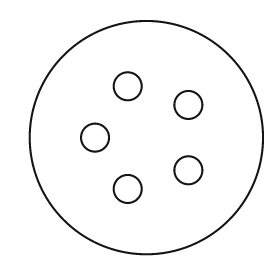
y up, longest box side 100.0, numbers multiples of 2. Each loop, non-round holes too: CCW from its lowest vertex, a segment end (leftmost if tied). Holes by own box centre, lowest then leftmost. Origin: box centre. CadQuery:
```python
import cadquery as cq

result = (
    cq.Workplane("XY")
    .moveTo(0.0, 0.0)
    .circle(50.0)
    .moveTo(-8.0, -22.0)
    .circle(6.0)
    .moveTo(18.0, -14.0)
    .circle(6.0)
    .moveTo(-22.0, 0.0)
    .circle(6.0)
    .moveTo(18.0, 14.0)
    .circle(6.0)
    .moveTo(-8.0, 22.0)
    .circle(6.0)
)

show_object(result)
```